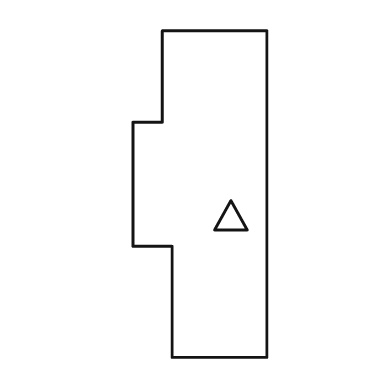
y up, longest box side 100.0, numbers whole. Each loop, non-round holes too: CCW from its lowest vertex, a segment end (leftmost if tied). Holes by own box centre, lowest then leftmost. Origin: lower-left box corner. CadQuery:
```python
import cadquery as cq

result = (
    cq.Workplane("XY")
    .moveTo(12.0, 0.0)
    .lineTo(41.0, 0.0)
    .lineTo(41.0, 100.0)
    .lineTo(9.0, 100.0)
    .lineTo(9.0, 72.0)
    .lineTo(0.0, 72.0)
    .lineTo(0.0, 34.0)
    .lineTo(12.0, 34.0)
    .close()
    .moveTo(25.0, 39.0)
    .lineTo(35.0, 39.0)
    .lineTo(30.0, 48.0)
    .close()
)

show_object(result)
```